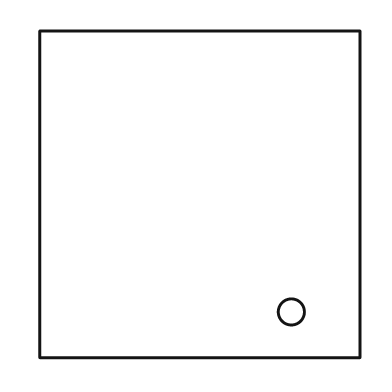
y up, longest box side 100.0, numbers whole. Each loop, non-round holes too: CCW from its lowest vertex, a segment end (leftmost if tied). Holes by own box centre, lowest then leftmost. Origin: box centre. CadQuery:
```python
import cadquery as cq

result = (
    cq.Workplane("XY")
    .moveTo(-49.0, -50.0)
    .lineTo(49.0, -50.0)
    .lineTo(49.0, 50.0)
    .lineTo(-49.0, 50.0)
    .close()
    .moveTo(28.0, -36.0)
    .circle(4.0)
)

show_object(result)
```